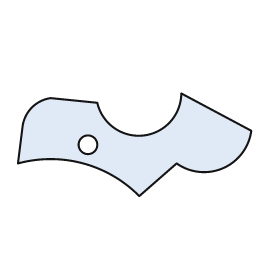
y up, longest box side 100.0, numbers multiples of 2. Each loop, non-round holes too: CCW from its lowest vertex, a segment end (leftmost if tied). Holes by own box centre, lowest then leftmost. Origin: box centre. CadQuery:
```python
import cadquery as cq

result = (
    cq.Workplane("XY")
    .moveTo(2.0, -22.0)
    .lineTo(18.0, -8.0)
    .threePointArc((38.0, -10.0), (50.0, 6.0))
    .lineTo(20.0, 22.0)
    .threePointArc((4.0, 4.0), (-16.0, 18.0))
    .lineTo(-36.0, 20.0)
    .threePointArc((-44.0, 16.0), (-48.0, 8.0))
    .lineTo(-50.0, -8.0)
    .threePointArc((-22.0, -8.0), (2.0, -22.0))
    .close()
    .moveTo(-20.0, 0.0)
    .circle(4.0)
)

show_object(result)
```